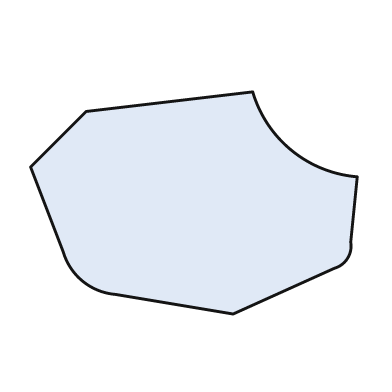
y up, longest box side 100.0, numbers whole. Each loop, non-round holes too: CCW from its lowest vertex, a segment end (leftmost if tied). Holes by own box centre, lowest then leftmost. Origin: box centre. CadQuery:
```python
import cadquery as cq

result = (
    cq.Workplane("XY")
    .moveTo(12.0, -34.0)
    .lineTo(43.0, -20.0)
    .threePointArc((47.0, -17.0), (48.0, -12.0))
    .lineTo(50.0, 8.0)
    .threePointArc((30.0, 16.0), (18.0, 34.0))
    .lineTo(-33.0, 28.0)
    .lineTo(-50.0, 11.0)
    .lineTo(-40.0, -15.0)
    .threePointArc((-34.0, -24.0), (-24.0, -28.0))
    .close()
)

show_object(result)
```